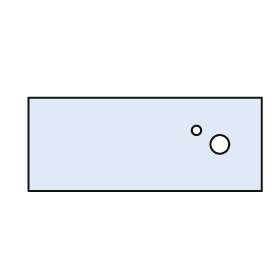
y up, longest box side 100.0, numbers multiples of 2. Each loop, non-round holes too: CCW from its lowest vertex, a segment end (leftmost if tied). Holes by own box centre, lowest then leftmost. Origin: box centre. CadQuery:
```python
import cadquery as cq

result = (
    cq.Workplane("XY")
    .moveTo(-50.0, -20.0)
    .lineTo(50.0, -20.0)
    .lineTo(50.0, 20.0)
    .lineTo(-50.0, 20.0)
    .close()
    .moveTo(32.0, 0.0)
    .circle(4.0)
    .moveTo(22.0, 6.0)
    .circle(2.0)
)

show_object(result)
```